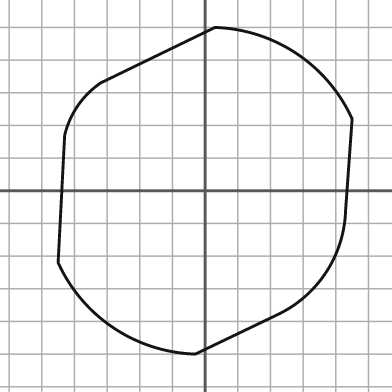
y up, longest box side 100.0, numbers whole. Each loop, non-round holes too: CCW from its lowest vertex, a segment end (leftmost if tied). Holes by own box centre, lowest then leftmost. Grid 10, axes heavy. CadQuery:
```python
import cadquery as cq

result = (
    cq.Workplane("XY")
    .moveTo(-3.0, -50.0)
    .lineTo(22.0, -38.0)
    .threePointArc((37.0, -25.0), (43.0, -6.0))
    .lineTo(45.0, 22.0)
    .threePointArc((28.0, 42.0), (3.0, 50.0))
    .lineTo(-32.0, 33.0)
    .threePointArc((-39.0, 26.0), (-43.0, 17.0))
    .lineTo(-45.0, -22.0)
    .threePointArc((-28.0, -42.0), (-3.0, -50.0))
    .close()
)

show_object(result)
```